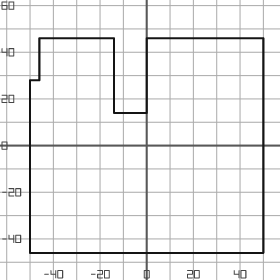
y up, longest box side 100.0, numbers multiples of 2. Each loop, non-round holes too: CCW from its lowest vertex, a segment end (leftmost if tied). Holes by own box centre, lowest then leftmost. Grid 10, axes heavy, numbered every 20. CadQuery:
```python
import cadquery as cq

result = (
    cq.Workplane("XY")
    .moveTo(-50.0, -46.0)
    .lineTo(50.0, -46.0)
    .lineTo(50.0, 46.0)
    .lineTo(0.0, 46.0)
    .lineTo(0.0, 14.0)
    .lineTo(-14.0, 14.0)
    .lineTo(-14.0, 46.0)
    .lineTo(-46.0, 46.0)
    .lineTo(-46.0, 28.0)
    .lineTo(-50.0, 28.0)
    .close()
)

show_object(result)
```